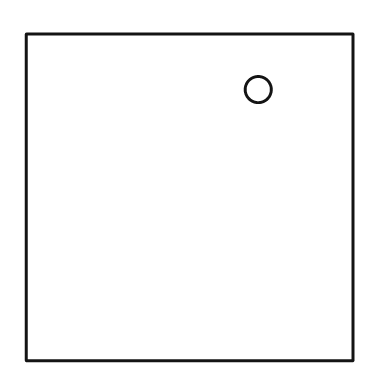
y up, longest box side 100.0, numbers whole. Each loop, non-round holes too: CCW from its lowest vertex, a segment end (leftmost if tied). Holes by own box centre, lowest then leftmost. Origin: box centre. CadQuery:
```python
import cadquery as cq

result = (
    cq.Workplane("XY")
    .moveTo(-50.0, -50.0)
    .lineTo(50.0, -50.0)
    .lineTo(50.0, 50.0)
    .lineTo(-50.0, 50.0)
    .close()
    .moveTo(21.0, 33.0)
    .circle(4.0)
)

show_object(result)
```